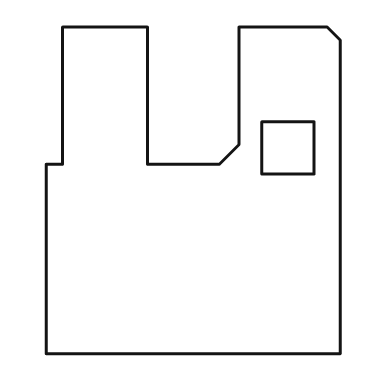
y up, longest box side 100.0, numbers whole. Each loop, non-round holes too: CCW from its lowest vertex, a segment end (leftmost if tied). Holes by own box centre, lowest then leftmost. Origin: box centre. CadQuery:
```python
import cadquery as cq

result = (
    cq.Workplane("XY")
    .moveTo(-45.0, -50.0)
    .lineTo(45.0, -50.0)
    .lineTo(45.0, 46.0)
    .lineTo(41.0, 50.0)
    .lineTo(14.0, 50.0)
    .lineTo(14.0, 14.0)
    .lineTo(8.0, 8.0)
    .lineTo(-14.0, 8.0)
    .lineTo(-14.0, 50.0)
    .lineTo(-40.0, 50.0)
    .lineTo(-40.0, 8.0)
    .lineTo(-45.0, 8.0)
    .close()
    .moveTo(21.0, 5.0)
    .lineTo(37.0, 5.0)
    .lineTo(37.0, 21.0)
    .lineTo(21.0, 21.0)
    .close()
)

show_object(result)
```